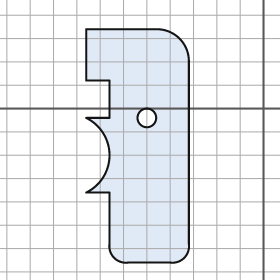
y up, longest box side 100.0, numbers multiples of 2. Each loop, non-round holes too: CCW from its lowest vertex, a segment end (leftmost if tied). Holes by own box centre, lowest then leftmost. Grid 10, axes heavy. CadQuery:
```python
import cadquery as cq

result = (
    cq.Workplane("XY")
    .moveTo(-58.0, -66.0)
    .lineTo(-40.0, -66.0)
    .threePointArc((-34.0, -64.0), (-32.0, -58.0))
    .lineTo(-32.0, 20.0)
    .threePointArc((-36.0, 30.0), (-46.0, 34.0))
    .lineTo(-76.0, 34.0)
    .lineTo(-76.0, 12.0)
    .lineTo(-66.0, 12.0)
    .lineTo(-66.0, -4.0)
    .lineTo(-76.0, -4.0)
    .threePointArc((-66.0, -20.0), (-76.0, -36.0))
    .lineTo(-66.0, -36.0)
    .lineTo(-66.0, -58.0)
    .threePointArc((-64.0, -64.0), (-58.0, -66.0))
    .close()
    .moveTo(-50.0, -4.0)
    .circle(4.0)
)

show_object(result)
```